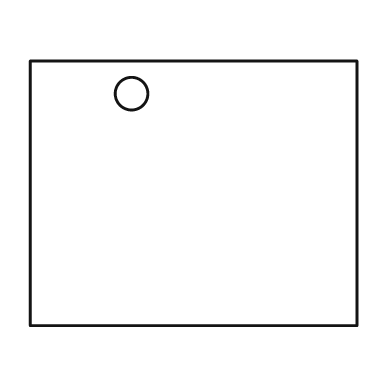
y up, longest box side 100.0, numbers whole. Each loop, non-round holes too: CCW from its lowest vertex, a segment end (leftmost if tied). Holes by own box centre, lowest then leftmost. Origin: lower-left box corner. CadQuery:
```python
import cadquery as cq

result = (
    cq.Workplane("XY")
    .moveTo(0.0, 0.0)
    .lineTo(100.0, 0.0)
    .lineTo(100.0, 81.0)
    .lineTo(0.0, 81.0)
    .close()
    .moveTo(31.0, 71.0)
    .circle(5.0)
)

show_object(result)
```